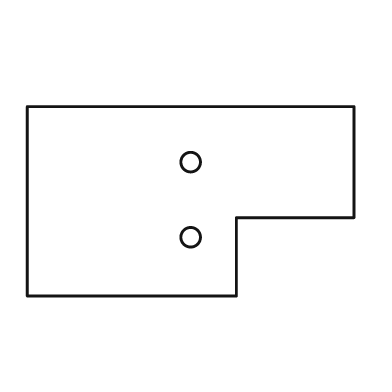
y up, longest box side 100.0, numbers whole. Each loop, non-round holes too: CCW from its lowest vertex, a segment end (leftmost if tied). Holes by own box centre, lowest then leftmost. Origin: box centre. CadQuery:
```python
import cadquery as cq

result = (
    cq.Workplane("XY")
    .moveTo(-50.0, -29.0)
    .lineTo(14.0, -29.0)
    .lineTo(14.0, -5.0)
    .lineTo(50.0, -5.0)
    .lineTo(50.0, 29.0)
    .lineTo(-50.0, 29.0)
    .close()
    .moveTo(0.0, -11.0)
    .circle(3.0)
    .moveTo(0.0, 12.0)
    .circle(3.0)
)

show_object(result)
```